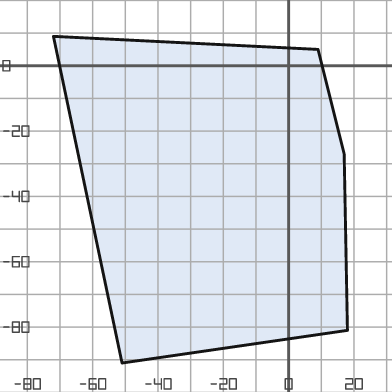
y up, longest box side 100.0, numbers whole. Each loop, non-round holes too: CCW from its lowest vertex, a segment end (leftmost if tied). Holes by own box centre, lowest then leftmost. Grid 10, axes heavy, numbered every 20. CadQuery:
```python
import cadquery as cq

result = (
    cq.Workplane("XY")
    .moveTo(-51.0, -91.0)
    .lineTo(18.0, -81.0)
    .lineTo(17.0, -27.0)
    .lineTo(9.0, 5.0)
    .lineTo(-72.0, 9.0)
    .close()
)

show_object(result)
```